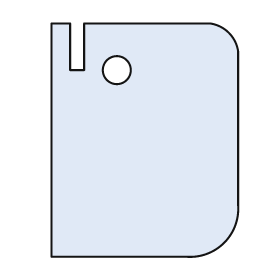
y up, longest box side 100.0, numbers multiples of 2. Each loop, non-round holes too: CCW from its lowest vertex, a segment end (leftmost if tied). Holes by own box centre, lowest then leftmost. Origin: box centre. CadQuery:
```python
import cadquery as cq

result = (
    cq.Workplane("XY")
    .moveTo(-40.0, -50.0)
    .lineTo(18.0, -50.0)
    .threePointArc((34.0, -44.0), (40.0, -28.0))
    .lineTo(40.0, 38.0)
    .threePointArc((36.0, 46.0), (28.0, 50.0))
    .lineTo(-26.0, 50.0)
    .lineTo(-26.0, 30.0)
    .lineTo(-32.0, 30.0)
    .lineTo(-32.0, 50.0)
    .lineTo(-40.0, 50.0)
    .close()
    .moveTo(-12.0, 30.0)
    .circle(6.0)
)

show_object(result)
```